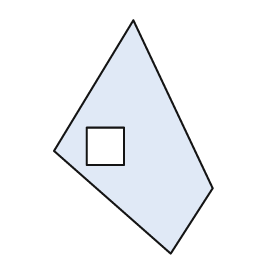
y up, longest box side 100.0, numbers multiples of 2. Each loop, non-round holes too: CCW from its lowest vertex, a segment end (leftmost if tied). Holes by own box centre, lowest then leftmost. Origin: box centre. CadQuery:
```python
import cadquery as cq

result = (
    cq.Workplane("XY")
    .moveTo(16.0, -50.0)
    .lineTo(34.0, -22.0)
    .lineTo(0.0, 50.0)
    .lineTo(-34.0, -6.0)
    .close()
    .moveTo(-20.0, -12.0)
    .lineTo(-4.0, -12.0)
    .lineTo(-4.0, 4.0)
    .lineTo(-20.0, 4.0)
    .close()
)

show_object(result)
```